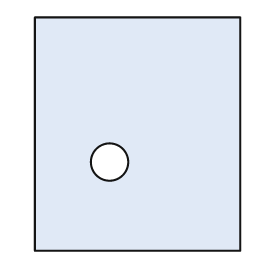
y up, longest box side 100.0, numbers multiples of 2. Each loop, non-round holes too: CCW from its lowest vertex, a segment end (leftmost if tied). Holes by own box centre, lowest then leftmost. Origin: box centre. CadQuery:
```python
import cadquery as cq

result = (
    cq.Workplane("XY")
    .moveTo(-44.0, -50.0)
    .lineTo(44.0, -50.0)
    .lineTo(44.0, 50.0)
    .lineTo(-44.0, 50.0)
    .close()
    .moveTo(-12.0, -12.0)
    .circle(8.0)
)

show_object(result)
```